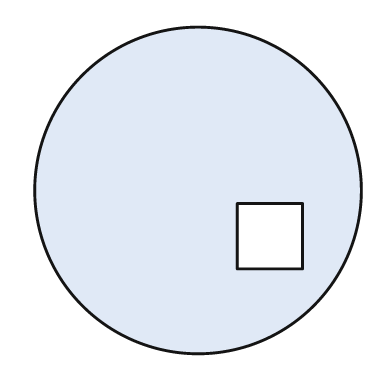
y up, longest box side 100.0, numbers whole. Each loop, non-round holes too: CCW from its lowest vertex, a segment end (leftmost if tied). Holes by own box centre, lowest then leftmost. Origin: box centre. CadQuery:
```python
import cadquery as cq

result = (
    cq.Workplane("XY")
    .moveTo(0.0, 0.0)
    .circle(50.0)
    .moveTo(12.0, -24.0)
    .lineTo(32.0, -24.0)
    .lineTo(32.0, -4.0)
    .lineTo(12.0, -4.0)
    .close()
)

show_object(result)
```